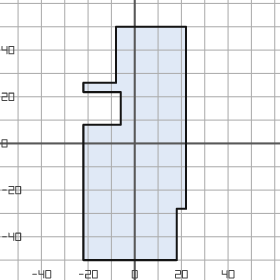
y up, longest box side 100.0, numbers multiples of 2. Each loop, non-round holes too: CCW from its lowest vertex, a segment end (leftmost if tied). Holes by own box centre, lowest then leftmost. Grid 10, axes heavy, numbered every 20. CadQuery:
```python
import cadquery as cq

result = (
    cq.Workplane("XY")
    .moveTo(-22.0, -50.0)
    .lineTo(18.0, -50.0)
    .lineTo(18.0, -28.0)
    .lineTo(22.0, -28.0)
    .lineTo(22.0, 50.0)
    .lineTo(-8.0, 50.0)
    .lineTo(-8.0, 26.0)
    .lineTo(-22.0, 26.0)
    .lineTo(-22.0, 22.0)
    .lineTo(-6.0, 22.0)
    .lineTo(-6.0, 8.0)
    .lineTo(-22.0, 8.0)
    .close()
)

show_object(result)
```